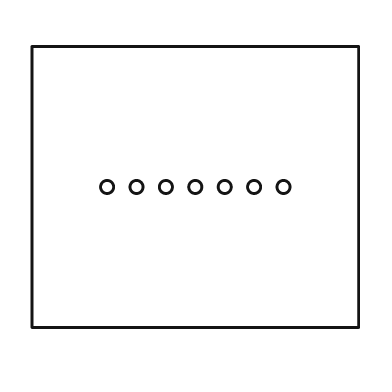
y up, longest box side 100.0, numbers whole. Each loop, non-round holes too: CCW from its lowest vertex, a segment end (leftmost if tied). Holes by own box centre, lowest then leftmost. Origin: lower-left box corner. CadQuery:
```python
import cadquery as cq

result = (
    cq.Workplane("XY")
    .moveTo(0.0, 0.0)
    .lineTo(100.0, 0.0)
    .lineTo(100.0, 86.0)
    .lineTo(0.0, 86.0)
    .close()
    .moveTo(23.0, 43.0)
    .circle(2.0)
    .moveTo(32.0, 43.0)
    .circle(2.0)
    .moveTo(41.0, 43.0)
    .circle(2.0)
    .moveTo(50.0, 43.0)
    .circle(2.0)
    .moveTo(59.0, 43.0)
    .circle(2.0)
    .moveTo(68.0, 43.0)
    .circle(2.0)
    .moveTo(77.0, 43.0)
    .circle(2.0)
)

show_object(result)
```